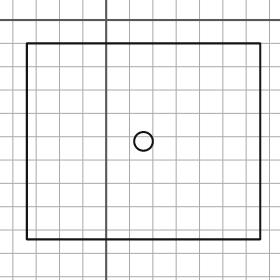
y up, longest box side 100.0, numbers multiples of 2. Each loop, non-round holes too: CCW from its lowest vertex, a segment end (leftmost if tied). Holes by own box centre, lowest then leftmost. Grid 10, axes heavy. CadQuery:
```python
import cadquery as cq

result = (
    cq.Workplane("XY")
    .moveTo(-34.0, -94.0)
    .lineTo(66.0, -94.0)
    .lineTo(66.0, -10.0)
    .lineTo(-34.0, -10.0)
    .close()
    .moveTo(16.0, -52.0)
    .circle(4.0)
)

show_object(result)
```